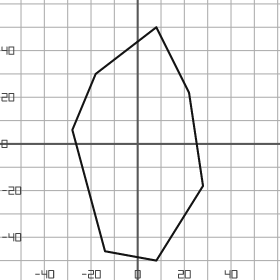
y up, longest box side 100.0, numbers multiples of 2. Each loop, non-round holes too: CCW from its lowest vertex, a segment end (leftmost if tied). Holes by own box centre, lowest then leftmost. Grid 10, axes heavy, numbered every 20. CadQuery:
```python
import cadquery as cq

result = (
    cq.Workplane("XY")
    .moveTo(8.0, -50.0)
    .lineTo(28.0, -18.0)
    .lineTo(22.0, 22.0)
    .lineTo(8.0, 50.0)
    .lineTo(-18.0, 30.0)
    .lineTo(-28.0, 6.0)
    .lineTo(-14.0, -46.0)
    .close()
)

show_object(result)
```